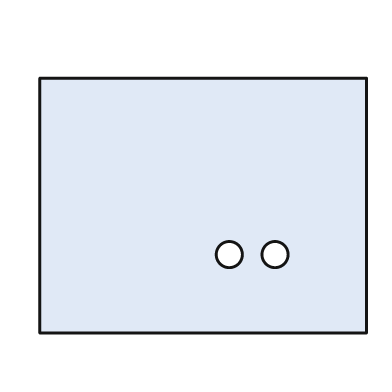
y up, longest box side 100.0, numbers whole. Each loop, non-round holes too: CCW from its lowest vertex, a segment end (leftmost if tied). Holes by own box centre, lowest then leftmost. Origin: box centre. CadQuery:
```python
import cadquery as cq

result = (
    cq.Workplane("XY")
    .moveTo(-50.0, -39.0)
    .lineTo(50.0, -39.0)
    .lineTo(50.0, 39.0)
    .lineTo(-50.0, 39.0)
    .close()
    .moveTo(8.0, -15.0)
    .circle(4.0)
    .moveTo(22.0, -15.0)
    .circle(4.0)
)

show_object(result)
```